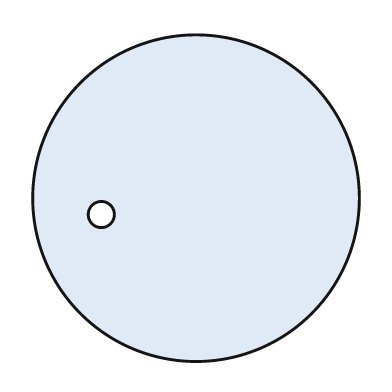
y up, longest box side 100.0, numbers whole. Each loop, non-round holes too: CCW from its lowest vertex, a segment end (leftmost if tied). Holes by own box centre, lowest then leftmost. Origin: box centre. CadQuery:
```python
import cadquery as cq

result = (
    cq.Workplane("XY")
    .moveTo(0.0, 0.0)
    .circle(50.0)
    .moveTo(-29.0, -5.0)
    .circle(4.0)
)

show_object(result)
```